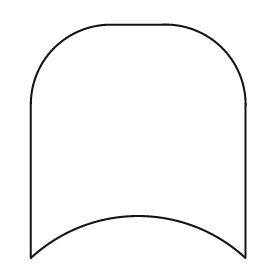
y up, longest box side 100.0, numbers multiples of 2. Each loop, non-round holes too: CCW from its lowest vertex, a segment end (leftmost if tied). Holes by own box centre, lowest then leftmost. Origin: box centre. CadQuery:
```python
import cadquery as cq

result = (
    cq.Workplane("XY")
    .moveTo(-46.0, -50.0)
    .threePointArc((0.0, -32.0), (46.0, -50.0))
    .lineTo(46.0, 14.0)
    .threePointArc((36.0, 40.0), (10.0, 50.0))
    .lineTo(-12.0, 50.0)
    .threePointArc((-36.0, 40.0), (-46.0, 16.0))
    .close()
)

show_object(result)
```